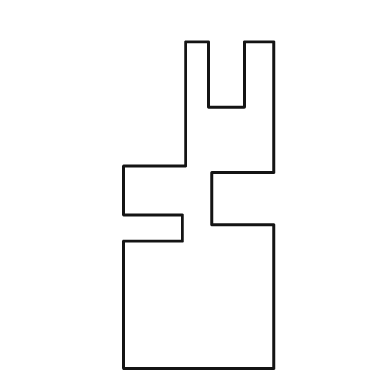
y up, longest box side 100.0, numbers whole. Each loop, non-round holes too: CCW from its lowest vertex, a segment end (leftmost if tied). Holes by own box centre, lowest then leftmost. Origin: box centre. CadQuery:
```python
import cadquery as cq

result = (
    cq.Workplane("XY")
    .moveTo(-23.0, -50.0)
    .lineTo(23.0, -50.0)
    .lineTo(23.0, -6.0)
    .lineTo(4.0, -6.0)
    .lineTo(4.0, 10.0)
    .lineTo(23.0, 10.0)
    .lineTo(23.0, 50.0)
    .lineTo(14.0, 50.0)
    .lineTo(14.0, 30.0)
    .lineTo(3.0, 30.0)
    .lineTo(3.0, 50.0)
    .lineTo(-4.0, 50.0)
    .lineTo(-4.0, 12.0)
    .lineTo(-23.0, 12.0)
    .lineTo(-23.0, -3.0)
    .lineTo(-5.0, -3.0)
    .lineTo(-5.0, -11.0)
    .lineTo(-23.0, -11.0)
    .close()
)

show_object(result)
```